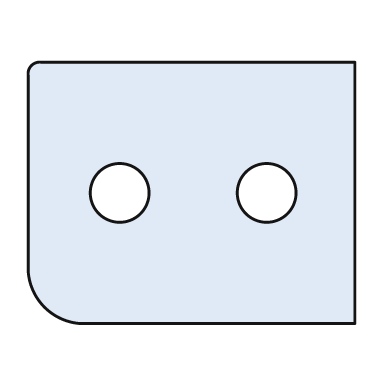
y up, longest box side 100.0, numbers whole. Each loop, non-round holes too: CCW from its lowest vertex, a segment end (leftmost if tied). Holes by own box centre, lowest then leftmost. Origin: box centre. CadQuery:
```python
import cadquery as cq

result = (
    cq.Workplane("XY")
    .moveTo(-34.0, -40.0)
    .lineTo(50.0, -40.0)
    .lineTo(50.0, 40.0)
    .lineTo(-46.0, 40.0)
    .threePointArc((-49.0, 39.0), (-50.0, 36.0))
    .lineTo(-50.0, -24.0)
    .threePointArc((-45.0, -35.0), (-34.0, -40.0))
    .close()
    .moveTo(-22.0, 0.0)
    .circle(9.0)
    .moveTo(23.0, 0.0)
    .circle(9.0)
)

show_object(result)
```